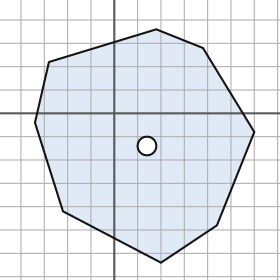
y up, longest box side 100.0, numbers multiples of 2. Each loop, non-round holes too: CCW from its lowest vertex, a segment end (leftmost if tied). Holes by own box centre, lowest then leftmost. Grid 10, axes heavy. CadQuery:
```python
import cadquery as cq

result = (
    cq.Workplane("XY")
    .moveTo(20.0, -64.0)
    .lineTo(44.0, -48.0)
    .lineTo(60.0, -8.0)
    .lineTo(38.0, 28.0)
    .lineTo(18.0, 36.0)
    .lineTo(-28.0, 22.0)
    .lineTo(-34.0, -4.0)
    .lineTo(-22.0, -42.0)
    .close()
    .moveTo(14.0, -14.0)
    .circle(4.0)
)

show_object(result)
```